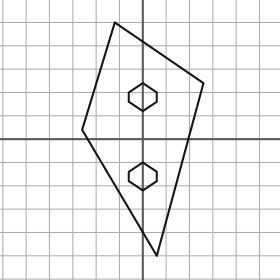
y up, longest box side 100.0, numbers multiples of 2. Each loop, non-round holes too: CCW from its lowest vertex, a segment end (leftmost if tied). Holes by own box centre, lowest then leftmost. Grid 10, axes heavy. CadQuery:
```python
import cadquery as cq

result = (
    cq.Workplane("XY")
    .moveTo(6.0, -50.0)
    .lineTo(26.0, 24.0)
    .lineTo(-12.0, 50.0)
    .lineTo(-26.0, 4.0)
    .close()
    .moveTo(0.0, -22.0)
    .lineTo(6.0, -18.0)
    .lineTo(6.0, -14.0)
    .lineTo(0.0, -10.0)
    .lineTo(-6.0, -14.0)
    .lineTo(-6.0, -18.0)
    .close()
    .moveTo(0.0, 12.0)
    .lineTo(6.0, 16.0)
    .lineTo(6.0, 20.0)
    .lineTo(0.0, 24.0)
    .lineTo(-6.0, 20.0)
    .lineTo(-6.0, 16.0)
    .close()
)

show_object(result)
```